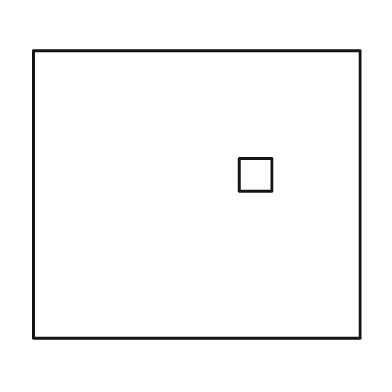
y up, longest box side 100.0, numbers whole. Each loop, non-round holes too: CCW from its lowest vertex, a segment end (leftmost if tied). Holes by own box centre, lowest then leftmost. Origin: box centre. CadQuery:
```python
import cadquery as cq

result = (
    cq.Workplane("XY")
    .moveTo(-50.0, -44.0)
    .lineTo(50.0, -44.0)
    .lineTo(50.0, 44.0)
    .lineTo(-50.0, 44.0)
    .close()
    .moveTo(13.0, 1.0)
    .lineTo(23.0, 1.0)
    .lineTo(23.0, 11.0)
    .lineTo(13.0, 11.0)
    .close()
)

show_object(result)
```